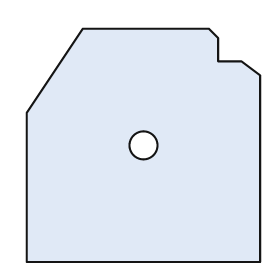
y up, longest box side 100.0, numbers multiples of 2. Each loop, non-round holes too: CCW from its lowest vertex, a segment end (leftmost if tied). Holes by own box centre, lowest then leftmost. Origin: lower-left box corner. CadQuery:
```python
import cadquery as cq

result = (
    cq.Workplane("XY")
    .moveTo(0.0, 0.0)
    .lineTo(100.0, 0.0)
    .lineTo(100.0, 80.0)
    .lineTo(92.0, 86.0)
    .lineTo(82.0, 86.0)
    .lineTo(82.0, 96.0)
    .lineTo(78.0, 100.0)
    .lineTo(24.0, 100.0)
    .lineTo(0.0, 64.0)
    .close()
    .moveTo(50.0, 50.0)
    .circle(6.0)
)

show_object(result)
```